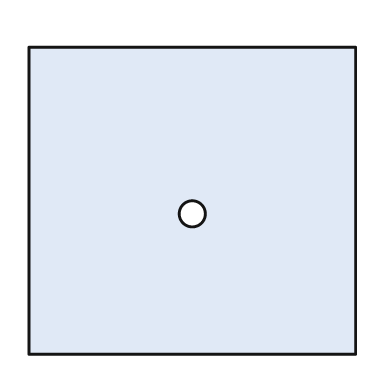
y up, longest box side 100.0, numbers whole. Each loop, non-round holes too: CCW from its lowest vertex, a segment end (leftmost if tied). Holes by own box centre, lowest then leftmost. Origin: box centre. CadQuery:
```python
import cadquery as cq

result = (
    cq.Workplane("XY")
    .moveTo(-50.0, -47.0)
    .lineTo(50.0, -47.0)
    .lineTo(50.0, 47.0)
    .lineTo(-50.0, 47.0)
    .close()
    .moveTo(0.0, -4.0)
    .circle(4.0)
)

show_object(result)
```